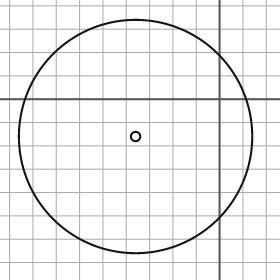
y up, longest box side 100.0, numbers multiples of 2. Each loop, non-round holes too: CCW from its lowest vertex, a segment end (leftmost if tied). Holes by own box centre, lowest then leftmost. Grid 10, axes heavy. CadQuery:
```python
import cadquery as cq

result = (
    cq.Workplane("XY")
    .moveTo(-36.0, -16.0)
    .circle(50.0)
    .moveTo(-36.0, -16.0)
    .circle(2.0)
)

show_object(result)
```